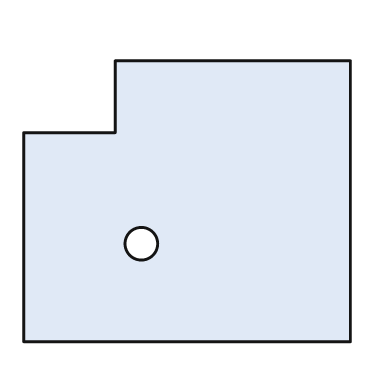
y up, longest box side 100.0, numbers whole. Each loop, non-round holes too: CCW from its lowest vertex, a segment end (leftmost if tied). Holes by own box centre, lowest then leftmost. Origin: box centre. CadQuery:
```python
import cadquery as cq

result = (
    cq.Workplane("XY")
    .moveTo(-50.0, -43.0)
    .lineTo(50.0, -43.0)
    .lineTo(50.0, 43.0)
    .lineTo(-22.0, 43.0)
    .lineTo(-22.0, 21.0)
    .lineTo(-50.0, 21.0)
    .close()
    .moveTo(-14.0, -13.0)
    .circle(5.0)
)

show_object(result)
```